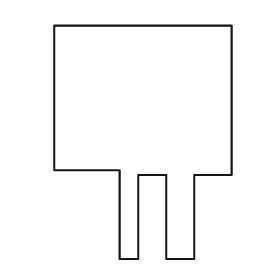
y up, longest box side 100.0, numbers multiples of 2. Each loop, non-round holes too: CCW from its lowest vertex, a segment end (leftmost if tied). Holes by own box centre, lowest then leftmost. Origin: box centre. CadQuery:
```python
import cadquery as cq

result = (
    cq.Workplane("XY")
    .moveTo(-10.0, -50.0)
    .lineTo(-2.0, -50.0)
    .lineTo(-2.0, -14.0)
    .lineTo(10.0, -14.0)
    .lineTo(10.0, -50.0)
    .lineTo(22.0, -50.0)
    .lineTo(22.0, -14.0)
    .lineTo(38.0, -14.0)
    .lineTo(38.0, 50.0)
    .lineTo(-38.0, 50.0)
    .lineTo(-38.0, -12.0)
    .lineTo(-10.0, -12.0)
    .close()
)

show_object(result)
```